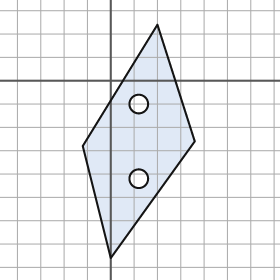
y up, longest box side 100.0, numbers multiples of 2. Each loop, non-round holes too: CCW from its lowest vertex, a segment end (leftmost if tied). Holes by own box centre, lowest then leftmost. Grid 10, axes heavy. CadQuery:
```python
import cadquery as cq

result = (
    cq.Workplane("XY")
    .moveTo(0.0, -76.0)
    .lineTo(36.0, -26.0)
    .lineTo(20.0, 24.0)
    .lineTo(-12.0, -28.0)
    .close()
    .moveTo(12.0, -42.0)
    .circle(4.0)
    .moveTo(12.0, -10.0)
    .circle(4.0)
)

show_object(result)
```